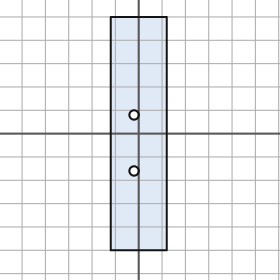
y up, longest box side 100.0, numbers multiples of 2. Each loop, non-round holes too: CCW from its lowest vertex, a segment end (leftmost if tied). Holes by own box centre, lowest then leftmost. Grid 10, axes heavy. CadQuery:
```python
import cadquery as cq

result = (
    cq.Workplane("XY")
    .moveTo(-12.0, -50.0)
    .lineTo(12.0, -50.0)
    .lineTo(12.0, 50.0)
    .lineTo(-12.0, 50.0)
    .close()
    .moveTo(-2.0, -16.0)
    .circle(2.0)
    .moveTo(-2.0, 8.0)
    .circle(2.0)
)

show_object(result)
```